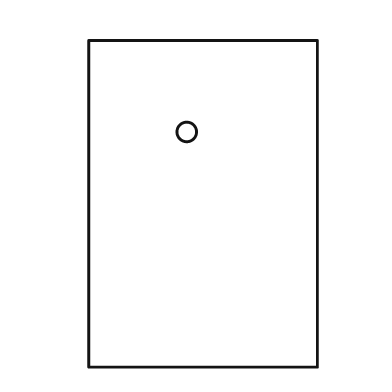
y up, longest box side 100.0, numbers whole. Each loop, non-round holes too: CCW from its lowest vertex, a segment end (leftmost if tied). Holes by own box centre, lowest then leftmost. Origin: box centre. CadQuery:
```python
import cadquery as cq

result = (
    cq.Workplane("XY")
    .moveTo(-35.0, -50.0)
    .lineTo(35.0, -50.0)
    .lineTo(35.0, 50.0)
    .lineTo(-35.0, 50.0)
    .close()
    .moveTo(-5.0, 22.0)
    .circle(3.0)
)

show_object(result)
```